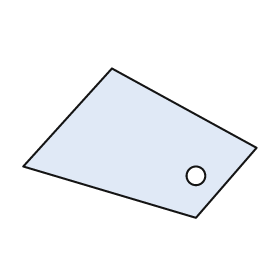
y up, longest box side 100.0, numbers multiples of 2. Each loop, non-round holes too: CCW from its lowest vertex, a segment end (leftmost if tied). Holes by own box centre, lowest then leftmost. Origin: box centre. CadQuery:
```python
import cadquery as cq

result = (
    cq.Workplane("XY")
    .moveTo(24.0, -32.0)
    .lineTo(50.0, -2.0)
    .lineTo(-12.0, 32.0)
    .lineTo(-50.0, -10.0)
    .close()
    .moveTo(24.0, -14.0)
    .circle(4.0)
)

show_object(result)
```